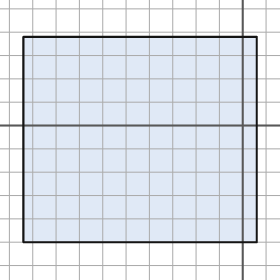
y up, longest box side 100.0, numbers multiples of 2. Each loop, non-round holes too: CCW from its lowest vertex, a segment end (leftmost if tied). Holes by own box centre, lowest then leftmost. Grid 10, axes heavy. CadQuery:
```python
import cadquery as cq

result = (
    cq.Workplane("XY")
    .moveTo(-94.0, -50.0)
    .lineTo(6.0, -50.0)
    .lineTo(6.0, 38.0)
    .lineTo(-94.0, 38.0)
    .close()
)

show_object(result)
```